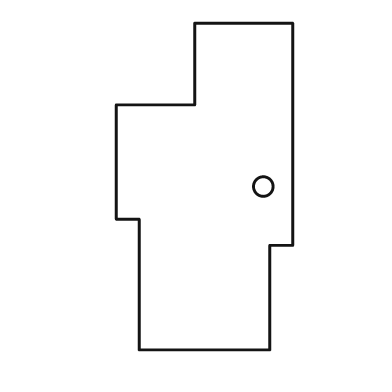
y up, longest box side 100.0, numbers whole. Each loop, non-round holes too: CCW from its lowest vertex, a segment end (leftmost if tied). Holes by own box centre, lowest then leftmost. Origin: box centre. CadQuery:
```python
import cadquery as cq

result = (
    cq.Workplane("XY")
    .moveTo(-20.0, -50.0)
    .lineTo(20.0, -50.0)
    .lineTo(20.0, -18.0)
    .lineTo(27.0, -18.0)
    .lineTo(27.0, 50.0)
    .lineTo(-3.0, 50.0)
    .lineTo(-3.0, 25.0)
    .lineTo(-27.0, 25.0)
    .lineTo(-27.0, -10.0)
    .lineTo(-20.0, -10.0)
    .close()
    .moveTo(18.0, 0.0)
    .circle(3.0)
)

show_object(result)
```